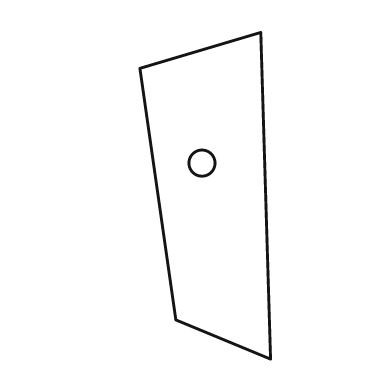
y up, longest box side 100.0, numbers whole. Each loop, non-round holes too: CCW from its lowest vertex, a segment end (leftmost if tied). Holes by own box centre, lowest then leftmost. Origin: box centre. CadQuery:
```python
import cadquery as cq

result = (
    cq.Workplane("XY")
    .moveTo(20.0, -50.0)
    .lineTo(17.0, 50.0)
    .lineTo(-20.0, 39.0)
    .lineTo(-9.0, -38.0)
    .close()
    .moveTo(-1.0, 10.0)
    .circle(4.0)
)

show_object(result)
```